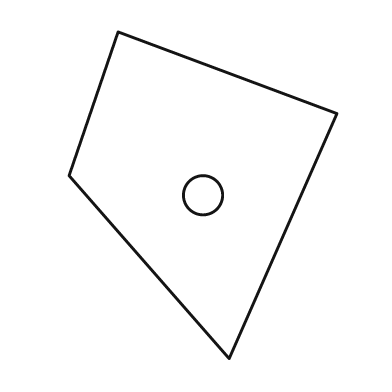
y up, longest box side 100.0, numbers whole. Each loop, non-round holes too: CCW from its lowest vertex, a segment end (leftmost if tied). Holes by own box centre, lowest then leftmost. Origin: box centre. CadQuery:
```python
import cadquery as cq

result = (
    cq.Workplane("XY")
    .moveTo(8.0, -50.0)
    .lineTo(41.0, 25.0)
    .lineTo(-26.0, 50.0)
    .lineTo(-41.0, 6.0)
    .close()
    .moveTo(0.0, 0.0)
    .circle(6.0)
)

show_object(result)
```